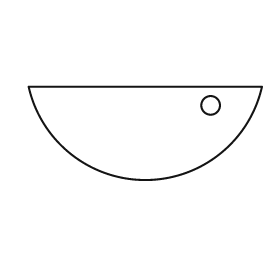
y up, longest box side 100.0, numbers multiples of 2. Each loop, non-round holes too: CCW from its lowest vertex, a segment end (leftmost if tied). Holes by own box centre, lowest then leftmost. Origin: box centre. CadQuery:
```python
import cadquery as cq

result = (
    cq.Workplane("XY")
    .moveTo(-50.0, 20.0)
    .threePointArc((0.0, -20.0), (50.0, 20.0))
    .close()
    .moveTo(28.0, 12.0)
    .circle(4.0)
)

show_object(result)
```